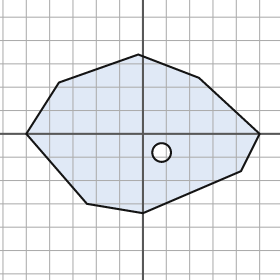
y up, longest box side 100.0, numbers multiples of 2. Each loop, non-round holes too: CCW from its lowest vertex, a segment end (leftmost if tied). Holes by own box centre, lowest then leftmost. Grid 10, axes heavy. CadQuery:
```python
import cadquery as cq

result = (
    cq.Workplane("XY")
    .moveTo(0.0, -34.0)
    .lineTo(42.0, -16.0)
    .lineTo(50.0, 0.0)
    .lineTo(24.0, 24.0)
    .lineTo(-2.0, 34.0)
    .lineTo(-36.0, 22.0)
    .lineTo(-50.0, 0.0)
    .lineTo(-24.0, -30.0)
    .close()
    .moveTo(8.0, -8.0)
    .circle(4.0)
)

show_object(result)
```